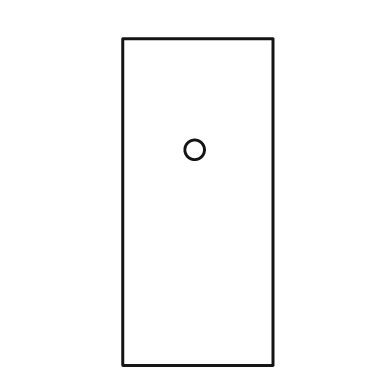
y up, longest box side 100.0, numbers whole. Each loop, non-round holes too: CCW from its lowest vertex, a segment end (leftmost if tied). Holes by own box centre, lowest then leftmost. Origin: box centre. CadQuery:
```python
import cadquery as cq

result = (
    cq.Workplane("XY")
    .moveTo(-23.0, -50.0)
    .lineTo(23.0, -50.0)
    .lineTo(23.0, 50.0)
    .lineTo(-23.0, 50.0)
    .close()
    .moveTo(-1.0, 16.0)
    .circle(3.0)
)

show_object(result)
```